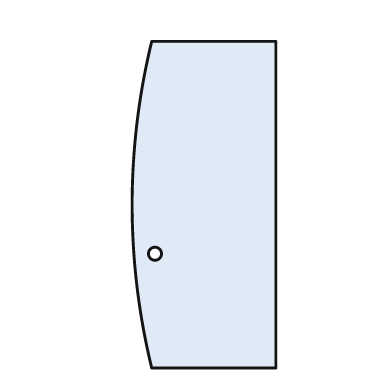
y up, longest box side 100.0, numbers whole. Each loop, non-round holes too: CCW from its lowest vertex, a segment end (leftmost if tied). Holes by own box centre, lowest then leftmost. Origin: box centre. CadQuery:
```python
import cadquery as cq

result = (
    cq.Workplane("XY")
    .moveTo(-16.0, -50.0)
    .lineTo(22.0, -50.0)
    .lineTo(22.0, 50.0)
    .lineTo(-16.0, 50.0)
    .threePointArc((-22.0, 0.0), (-16.0, -50.0))
    .close()
    .moveTo(-15.0, -15.0)
    .circle(2.0)
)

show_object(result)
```